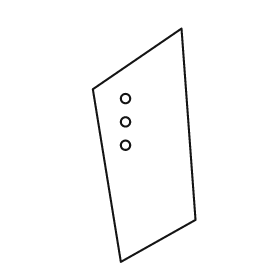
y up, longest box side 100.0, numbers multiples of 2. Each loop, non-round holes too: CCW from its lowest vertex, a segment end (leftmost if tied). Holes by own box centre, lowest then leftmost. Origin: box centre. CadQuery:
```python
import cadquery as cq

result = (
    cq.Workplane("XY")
    .moveTo(-10.0, -50.0)
    .lineTo(22.0, -32.0)
    .lineTo(16.0, 50.0)
    .lineTo(-22.0, 24.0)
    .close()
    .moveTo(-8.0, 0.0)
    .circle(2.0)
    .moveTo(-8.0, 10.0)
    .circle(2.0)
    .moveTo(-8.0, 20.0)
    .circle(2.0)
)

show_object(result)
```